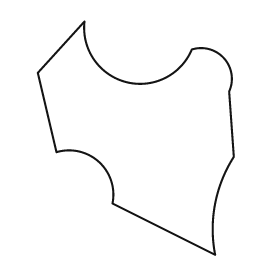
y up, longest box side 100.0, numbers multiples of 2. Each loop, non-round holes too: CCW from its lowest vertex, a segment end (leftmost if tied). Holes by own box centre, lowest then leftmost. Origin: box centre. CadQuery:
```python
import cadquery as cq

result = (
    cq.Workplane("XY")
    .moveTo(34.0, -50.0)
    .threePointArc((34.0, -28.0), (42.0, -8.0))
    .lineTo(40.0, 20.0)
    .threePointArc((38.0, 34.0), (24.0, 38.0))
    .threePointArc((-4.0, 24.0), (-22.0, 50.0))
    .lineTo(-42.0, 28.0)
    .lineTo(-34.0, -6.0)
    .threePointArc((-16.0, -10.0), (-10.0, -28.0))
    .close()
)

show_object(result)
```